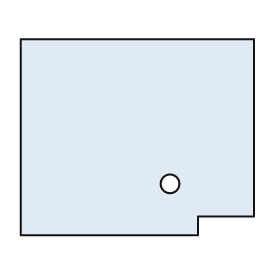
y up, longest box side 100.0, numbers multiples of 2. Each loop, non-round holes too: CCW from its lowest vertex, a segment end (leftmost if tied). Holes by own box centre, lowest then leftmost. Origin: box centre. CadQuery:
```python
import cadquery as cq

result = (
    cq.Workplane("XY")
    .moveTo(-50.0, -42.0)
    .lineTo(26.0, -42.0)
    .lineTo(26.0, -34.0)
    .lineTo(50.0, -34.0)
    .lineTo(50.0, 42.0)
    .lineTo(-50.0, 42.0)
    .close()
    .moveTo(14.0, -20.0)
    .circle(4.0)
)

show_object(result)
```